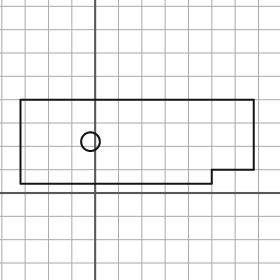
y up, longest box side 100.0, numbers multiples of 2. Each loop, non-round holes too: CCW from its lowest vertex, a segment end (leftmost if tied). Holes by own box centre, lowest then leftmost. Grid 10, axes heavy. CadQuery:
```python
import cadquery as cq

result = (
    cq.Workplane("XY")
    .moveTo(-32.0, 4.0)
    .lineTo(50.0, 4.0)
    .lineTo(50.0, 10.0)
    .lineTo(68.0, 10.0)
    .lineTo(68.0, 40.0)
    .lineTo(-32.0, 40.0)
    .close()
    .moveTo(-2.0, 22.0)
    .circle(4.0)
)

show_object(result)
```